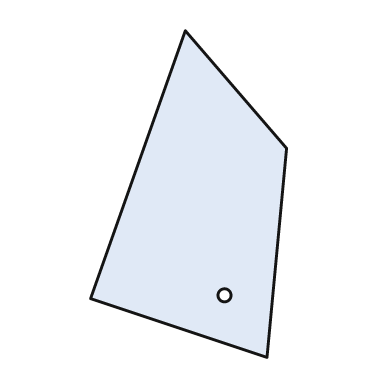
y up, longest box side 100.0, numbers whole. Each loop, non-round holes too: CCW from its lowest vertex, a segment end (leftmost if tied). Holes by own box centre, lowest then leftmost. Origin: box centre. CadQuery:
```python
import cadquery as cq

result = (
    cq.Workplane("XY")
    .moveTo(24.0, -50.0)
    .lineTo(30.0, 14.0)
    .lineTo(-1.0, 50.0)
    .lineTo(-30.0, -32.0)
    .close()
    .moveTo(11.0, -31.0)
    .circle(2.0)
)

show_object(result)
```